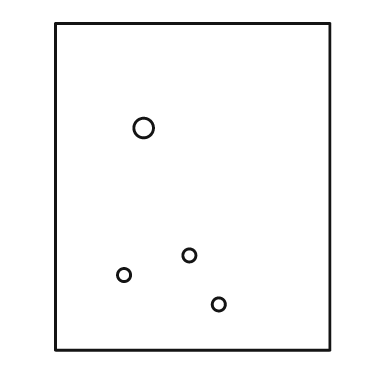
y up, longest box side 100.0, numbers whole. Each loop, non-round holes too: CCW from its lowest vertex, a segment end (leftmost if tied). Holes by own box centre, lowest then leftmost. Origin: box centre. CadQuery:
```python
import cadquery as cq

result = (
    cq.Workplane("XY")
    .moveTo(-42.0, -50.0)
    .lineTo(42.0, -50.0)
    .lineTo(42.0, 50.0)
    .lineTo(-42.0, 50.0)
    .close()
    .moveTo(8.0, -36.0)
    .circle(2.0)
    .moveTo(-21.0, -27.0)
    .circle(2.0)
    .moveTo(-1.0, -21.0)
    .circle(2.0)
    .moveTo(-15.0, 18.0)
    .circle(3.0)
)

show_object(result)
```